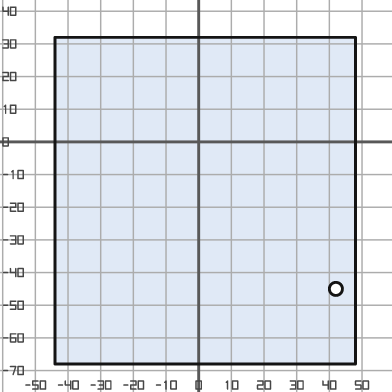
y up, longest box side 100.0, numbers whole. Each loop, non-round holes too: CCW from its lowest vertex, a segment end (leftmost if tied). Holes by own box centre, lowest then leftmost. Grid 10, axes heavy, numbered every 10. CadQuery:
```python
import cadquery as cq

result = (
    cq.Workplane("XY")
    .moveTo(-44.0, -68.0)
    .lineTo(48.0, -68.0)
    .lineTo(48.0, 32.0)
    .lineTo(-44.0, 32.0)
    .close()
    .moveTo(42.0, -45.0)
    .circle(2.0)
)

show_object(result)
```